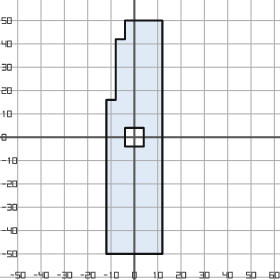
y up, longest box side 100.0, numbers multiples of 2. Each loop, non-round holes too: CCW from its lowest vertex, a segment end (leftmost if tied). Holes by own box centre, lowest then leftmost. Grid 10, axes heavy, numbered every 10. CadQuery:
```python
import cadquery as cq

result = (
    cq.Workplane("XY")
    .moveTo(-12.0, -50.0)
    .lineTo(12.0, -50.0)
    .lineTo(12.0, 50.0)
    .lineTo(-4.0, 50.0)
    .lineTo(-4.0, 42.0)
    .lineTo(-8.0, 42.0)
    .lineTo(-8.0, 16.0)
    .lineTo(-12.0, 16.0)
    .close()
    .moveTo(-4.0, -4.0)
    .lineTo(4.0, -4.0)
    .lineTo(4.0, 4.0)
    .lineTo(-4.0, 4.0)
    .close()
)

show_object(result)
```